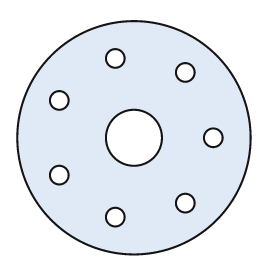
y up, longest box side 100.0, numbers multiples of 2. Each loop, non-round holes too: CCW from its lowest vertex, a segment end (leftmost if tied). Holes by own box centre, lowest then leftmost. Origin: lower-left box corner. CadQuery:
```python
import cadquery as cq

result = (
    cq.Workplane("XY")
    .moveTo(50.0, 50.0)
    .circle(50.0)
    .moveTo(42.0, 16.0)
    .circle(4.0)
    .moveTo(72.0, 22.0)
    .circle(4.0)
    .moveTo(18.0, 34.0)
    .circle(4.0)
    .moveTo(50.0, 50.0)
    .circle(12.0)
    .moveTo(84.0, 50.0)
    .circle(4.0)
    .moveTo(18.0, 66.0)
    .circle(4.0)
    .moveTo(72.0, 78.0)
    .circle(4.0)
    .moveTo(42.0, 84.0)
    .circle(4.0)
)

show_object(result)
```